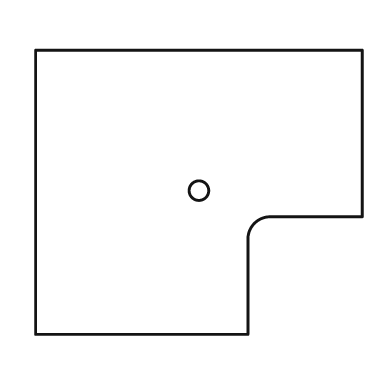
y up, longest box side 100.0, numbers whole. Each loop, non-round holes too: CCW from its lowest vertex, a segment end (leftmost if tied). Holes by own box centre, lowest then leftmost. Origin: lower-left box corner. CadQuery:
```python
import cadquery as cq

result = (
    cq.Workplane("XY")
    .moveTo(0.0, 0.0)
    .lineTo(65.0, 0.0)
    .lineTo(65.0, 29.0)
    .threePointArc((67.0, 34.0), (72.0, 36.0))
    .lineTo(100.0, 36.0)
    .lineTo(100.0, 87.0)
    .lineTo(0.0, 87.0)
    .close()
    .moveTo(50.0, 44.0)
    .circle(3.0)
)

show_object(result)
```